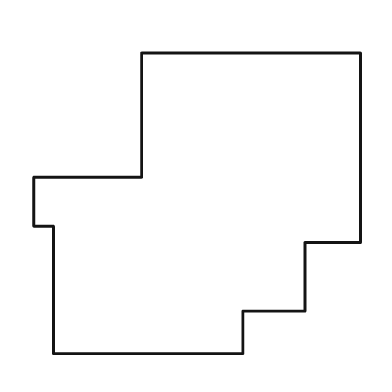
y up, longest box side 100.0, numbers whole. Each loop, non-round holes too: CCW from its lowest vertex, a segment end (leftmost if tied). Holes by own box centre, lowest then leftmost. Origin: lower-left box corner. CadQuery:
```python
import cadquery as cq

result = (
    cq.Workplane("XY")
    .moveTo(6.0, 0.0)
    .lineTo(64.0, 0.0)
    .lineTo(64.0, 13.0)
    .lineTo(83.0, 13.0)
    .lineTo(83.0, 34.0)
    .lineTo(100.0, 34.0)
    .lineTo(100.0, 92.0)
    .lineTo(33.0, 92.0)
    .lineTo(33.0, 54.0)
    .lineTo(0.0, 54.0)
    .lineTo(0.0, 39.0)
    .lineTo(6.0, 39.0)
    .close()
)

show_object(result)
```